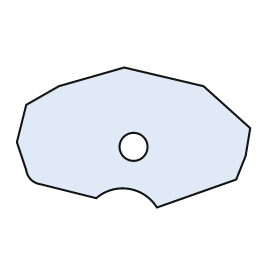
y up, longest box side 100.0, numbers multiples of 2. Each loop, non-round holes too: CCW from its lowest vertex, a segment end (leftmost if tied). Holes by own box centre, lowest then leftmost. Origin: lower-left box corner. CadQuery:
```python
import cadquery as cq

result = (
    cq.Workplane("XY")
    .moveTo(60.0, 0.0)
    .lineTo(94.0, 12.0)
    .lineTo(98.0, 22.0)
    .lineTo(100.0, 34.0)
    .lineTo(80.0, 52.0)
    .lineTo(46.0, 60.0)
    .lineTo(18.0, 52.0)
    .lineTo(4.0, 44.0)
    .lineTo(0.0, 28.0)
    .lineTo(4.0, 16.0)
    .threePointArc((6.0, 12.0), (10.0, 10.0))
    .lineTo(34.0, 4.0)
    .threePointArc((48.0, 8.0), (60.0, 0.0))
    .close()
    .moveTo(50.0, 26.0)
    .circle(6.0)
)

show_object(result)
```